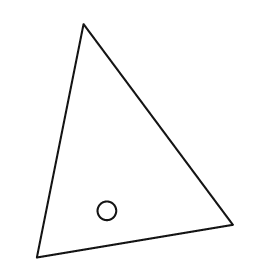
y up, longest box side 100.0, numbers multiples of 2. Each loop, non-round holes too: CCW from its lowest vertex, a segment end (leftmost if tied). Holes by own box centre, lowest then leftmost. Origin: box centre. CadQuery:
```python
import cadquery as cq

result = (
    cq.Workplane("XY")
    .moveTo(-42.0, -50.0)
    .lineTo(42.0, -36.0)
    .lineTo(-22.0, 50.0)
    .close()
    .moveTo(-12.0, -30.0)
    .circle(4.0)
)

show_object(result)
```